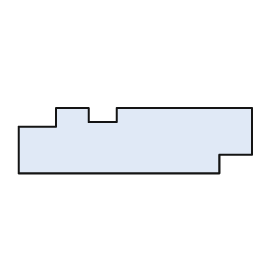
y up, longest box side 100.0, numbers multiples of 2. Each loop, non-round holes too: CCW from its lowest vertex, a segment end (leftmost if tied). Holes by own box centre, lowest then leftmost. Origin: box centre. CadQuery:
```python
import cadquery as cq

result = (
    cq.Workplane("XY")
    .moveTo(-50.0, -14.0)
    .lineTo(36.0, -14.0)
    .lineTo(36.0, -6.0)
    .lineTo(50.0, -6.0)
    .lineTo(50.0, 14.0)
    .lineTo(-8.0, 14.0)
    .lineTo(-8.0, 8.0)
    .lineTo(-20.0, 8.0)
    .lineTo(-20.0, 14.0)
    .lineTo(-34.0, 14.0)
    .lineTo(-34.0, 6.0)
    .lineTo(-50.0, 6.0)
    .close()
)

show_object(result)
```